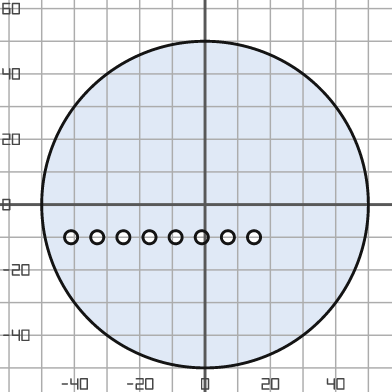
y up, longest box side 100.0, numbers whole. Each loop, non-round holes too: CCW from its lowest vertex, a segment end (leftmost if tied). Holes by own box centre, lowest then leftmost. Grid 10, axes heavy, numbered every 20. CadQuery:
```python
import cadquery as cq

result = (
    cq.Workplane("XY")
    .moveTo(0.0, 0.0)
    .circle(50.0)
    .moveTo(-41.0, -10.0)
    .circle(2.0)
    .moveTo(-33.0, -10.0)
    .circle(2.0)
    .moveTo(-25.0, -10.0)
    .circle(2.0)
    .moveTo(-17.0, -10.0)
    .circle(2.0)
    .moveTo(-9.0, -10.0)
    .circle(2.0)
    .moveTo(-1.0, -10.0)
    .circle(2.0)
    .moveTo(7.0, -10.0)
    .circle(2.0)
    .moveTo(15.0, -10.0)
    .circle(2.0)
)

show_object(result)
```